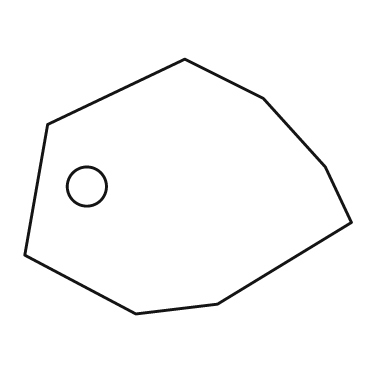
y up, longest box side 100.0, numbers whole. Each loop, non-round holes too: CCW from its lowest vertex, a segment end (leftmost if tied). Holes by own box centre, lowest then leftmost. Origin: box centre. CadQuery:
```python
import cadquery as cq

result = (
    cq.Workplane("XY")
    .moveTo(-16.0, -39.0)
    .lineTo(9.0, -36.0)
    .lineTo(50.0, -11.0)
    .lineTo(42.0, 6.0)
    .lineTo(23.0, 27.0)
    .lineTo(-1.0, 39.0)
    .lineTo(-43.0, 19.0)
    .lineTo(-50.0, -21.0)
    .close()
    .moveTo(-31.0, 0.0)
    .circle(6.0)
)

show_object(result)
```